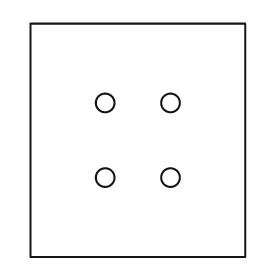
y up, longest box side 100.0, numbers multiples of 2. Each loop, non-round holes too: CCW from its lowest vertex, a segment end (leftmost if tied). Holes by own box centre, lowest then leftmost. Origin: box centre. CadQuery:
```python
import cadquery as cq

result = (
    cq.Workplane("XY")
    .moveTo(-46.0, -50.0)
    .lineTo(46.0, -50.0)
    .lineTo(46.0, 50.0)
    .lineTo(-46.0, 50.0)
    .close()
    .moveTo(-14.0, -16.0)
    .circle(4.0)
    .moveTo(14.0, -16.0)
    .circle(4.0)
    .moveTo(-14.0, 16.0)
    .circle(4.0)
    .moveTo(14.0, 16.0)
    .circle(4.0)
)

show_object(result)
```